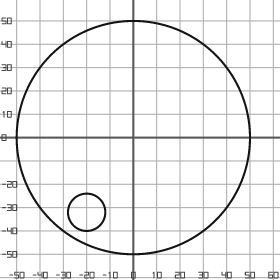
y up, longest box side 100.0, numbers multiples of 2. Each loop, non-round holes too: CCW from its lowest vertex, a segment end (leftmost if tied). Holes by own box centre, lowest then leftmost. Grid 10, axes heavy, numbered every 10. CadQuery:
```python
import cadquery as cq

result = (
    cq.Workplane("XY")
    .moveTo(0.0, 0.0)
    .circle(50.0)
    .moveTo(-20.0, -32.0)
    .circle(8.0)
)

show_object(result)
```